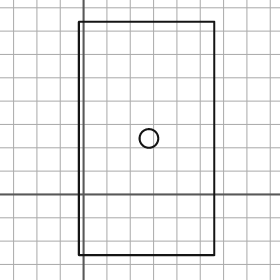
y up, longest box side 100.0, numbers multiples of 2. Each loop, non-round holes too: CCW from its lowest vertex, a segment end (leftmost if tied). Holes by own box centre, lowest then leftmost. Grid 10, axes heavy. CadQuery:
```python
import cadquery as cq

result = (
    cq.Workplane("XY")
    .moveTo(-2.0, -26.0)
    .lineTo(56.0, -26.0)
    .lineTo(56.0, 74.0)
    .lineTo(-2.0, 74.0)
    .close()
    .moveTo(28.0, 24.0)
    .circle(4.0)
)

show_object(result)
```